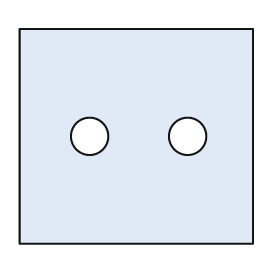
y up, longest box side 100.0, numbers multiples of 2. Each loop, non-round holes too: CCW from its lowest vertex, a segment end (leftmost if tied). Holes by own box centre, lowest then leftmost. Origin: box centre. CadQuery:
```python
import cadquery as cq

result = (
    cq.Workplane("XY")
    .moveTo(-50.0, -46.0)
    .lineTo(50.0, -46.0)
    .lineTo(50.0, 46.0)
    .lineTo(-50.0, 46.0)
    .close()
    .moveTo(-20.0, 0.0)
    .circle(8.0)
    .moveTo(22.0, 0.0)
    .circle(8.0)
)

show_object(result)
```